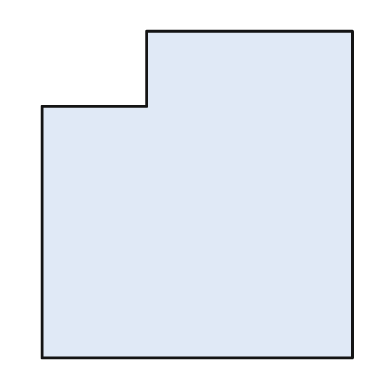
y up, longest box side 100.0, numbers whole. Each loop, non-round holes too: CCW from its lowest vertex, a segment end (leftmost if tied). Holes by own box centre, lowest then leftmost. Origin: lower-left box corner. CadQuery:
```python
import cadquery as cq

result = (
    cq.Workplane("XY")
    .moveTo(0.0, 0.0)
    .lineTo(95.0, 0.0)
    .lineTo(95.0, 100.0)
    .lineTo(32.0, 100.0)
    .lineTo(32.0, 77.0)
    .lineTo(0.0, 77.0)
    .close()
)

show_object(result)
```